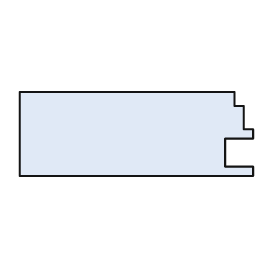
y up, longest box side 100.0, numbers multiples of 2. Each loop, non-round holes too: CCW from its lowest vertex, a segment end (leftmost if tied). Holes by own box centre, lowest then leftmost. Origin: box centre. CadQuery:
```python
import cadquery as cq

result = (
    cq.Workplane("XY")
    .moveTo(-50.0, -18.0)
    .lineTo(50.0, -18.0)
    .lineTo(50.0, -14.0)
    .lineTo(38.0, -14.0)
    .lineTo(38.0, -2.0)
    .lineTo(50.0, -2.0)
    .lineTo(50.0, 2.0)
    .lineTo(46.0, 2.0)
    .lineTo(46.0, 12.0)
    .lineTo(42.0, 12.0)
    .lineTo(42.0, 18.0)
    .lineTo(-50.0, 18.0)
    .close()
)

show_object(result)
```